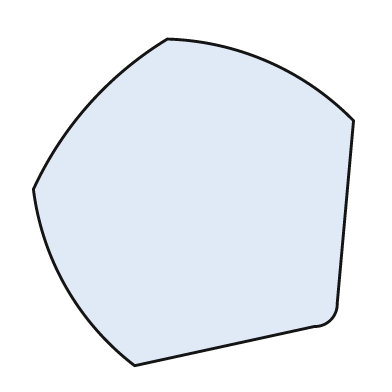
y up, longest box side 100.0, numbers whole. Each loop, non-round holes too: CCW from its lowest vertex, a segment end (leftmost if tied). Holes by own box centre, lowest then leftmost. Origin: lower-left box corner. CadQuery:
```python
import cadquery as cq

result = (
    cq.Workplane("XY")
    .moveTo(31.0, 0.0)
    .lineTo(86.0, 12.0)
    .threePointArc((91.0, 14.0), (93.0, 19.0))
    .lineTo(98.0, 75.0)
    .threePointArc((72.0, 93.0), (41.0, 100.0))
    .threePointArc((17.0, 80.0), (0.0, 54.0))
    .threePointArc((10.0, 24.0), (31.0, 0.0))
    .close()
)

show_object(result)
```